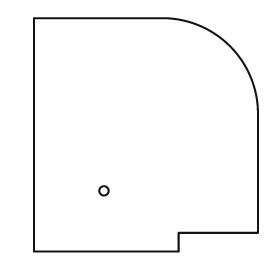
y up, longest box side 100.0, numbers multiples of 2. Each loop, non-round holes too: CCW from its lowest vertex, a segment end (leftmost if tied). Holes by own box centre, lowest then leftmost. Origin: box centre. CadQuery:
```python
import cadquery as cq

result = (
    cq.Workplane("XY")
    .moveTo(-48.0, -50.0)
    .lineTo(14.0, -50.0)
    .lineTo(14.0, -42.0)
    .lineTo(48.0, -42.0)
    .lineTo(48.0, 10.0)
    .threePointArc((36.0, 38.0), (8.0, 50.0))
    .lineTo(-48.0, 50.0)
    .close()
    .moveTo(-18.0, -24.0)
    .circle(2.0)
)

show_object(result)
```